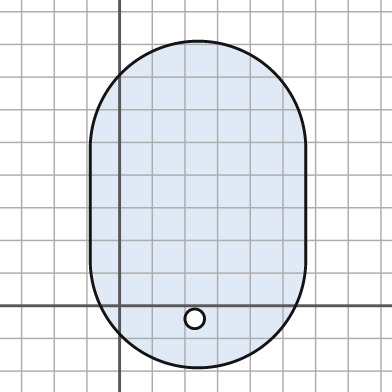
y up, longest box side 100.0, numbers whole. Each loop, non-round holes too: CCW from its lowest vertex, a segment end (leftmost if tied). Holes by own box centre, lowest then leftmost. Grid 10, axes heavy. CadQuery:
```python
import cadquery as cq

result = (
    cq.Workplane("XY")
    .moveTo(-9.0, 14.0)
    .threePointArc((24.0, -19.0), (57.0, 14.0))
    .lineTo(57.0, 48.0)
    .threePointArc((24.0, 81.0), (-9.0, 48.0))
    .close()
    .moveTo(23.0, -4.0)
    .circle(3.0)
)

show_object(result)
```